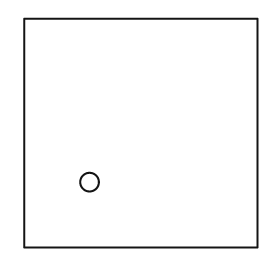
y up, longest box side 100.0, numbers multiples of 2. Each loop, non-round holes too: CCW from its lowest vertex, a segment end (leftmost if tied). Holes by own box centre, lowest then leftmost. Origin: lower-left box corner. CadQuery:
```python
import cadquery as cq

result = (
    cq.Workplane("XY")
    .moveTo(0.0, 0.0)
    .lineTo(100.0, 0.0)
    .lineTo(100.0, 98.0)
    .lineTo(0.0, 98.0)
    .close()
    .moveTo(28.0, 28.0)
    .circle(4.0)
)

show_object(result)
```